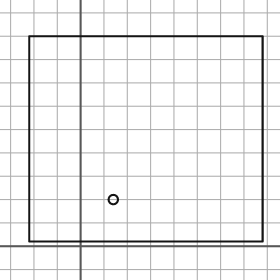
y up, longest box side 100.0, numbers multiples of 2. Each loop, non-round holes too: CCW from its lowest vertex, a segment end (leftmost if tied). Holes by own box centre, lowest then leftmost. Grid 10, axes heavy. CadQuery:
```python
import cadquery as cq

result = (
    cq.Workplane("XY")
    .moveTo(-22.0, 2.0)
    .lineTo(78.0, 2.0)
    .lineTo(78.0, 90.0)
    .lineTo(-22.0, 90.0)
    .close()
    .moveTo(14.0, 20.0)
    .circle(2.0)
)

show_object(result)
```